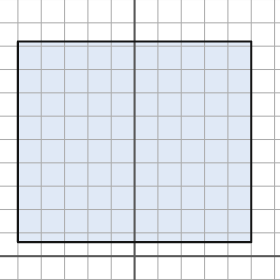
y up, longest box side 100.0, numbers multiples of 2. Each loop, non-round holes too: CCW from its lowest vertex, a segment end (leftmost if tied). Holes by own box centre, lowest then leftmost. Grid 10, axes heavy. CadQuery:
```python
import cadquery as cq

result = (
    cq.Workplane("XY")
    .moveTo(-50.0, 6.0)
    .lineTo(50.0, 6.0)
    .lineTo(50.0, 92.0)
    .lineTo(-50.0, 92.0)
    .close()
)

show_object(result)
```